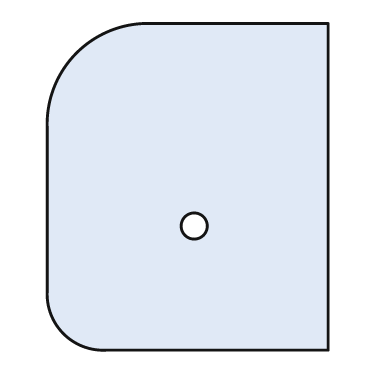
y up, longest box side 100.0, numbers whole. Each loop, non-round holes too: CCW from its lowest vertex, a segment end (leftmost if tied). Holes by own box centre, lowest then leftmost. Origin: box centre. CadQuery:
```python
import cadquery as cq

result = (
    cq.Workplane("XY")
    .moveTo(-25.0, -50.0)
    .lineTo(43.0, -50.0)
    .lineTo(43.0, 50.0)
    .lineTo(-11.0, 50.0)
    .threePointArc((-34.0, 41.0), (-43.0, 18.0))
    .lineTo(-43.0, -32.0)
    .threePointArc((-38.0, -45.0), (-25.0, -50.0))
    .close()
    .moveTo(2.0, -12.0)
    .circle(4.0)
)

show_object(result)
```